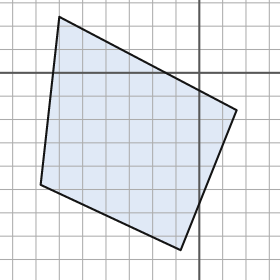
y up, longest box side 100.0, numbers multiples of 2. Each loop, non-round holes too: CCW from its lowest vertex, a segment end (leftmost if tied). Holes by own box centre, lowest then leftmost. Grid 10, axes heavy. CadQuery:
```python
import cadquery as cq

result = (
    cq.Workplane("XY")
    .moveTo(-8.0, -76.0)
    .lineTo(16.0, -16.0)
    .lineTo(-60.0, 24.0)
    .lineTo(-68.0, -48.0)
    .close()
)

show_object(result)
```